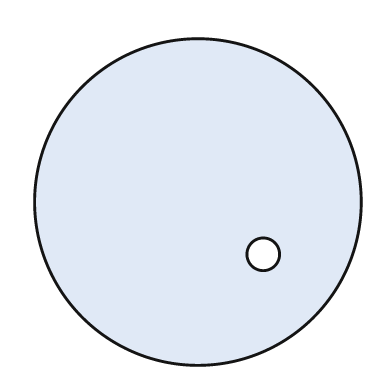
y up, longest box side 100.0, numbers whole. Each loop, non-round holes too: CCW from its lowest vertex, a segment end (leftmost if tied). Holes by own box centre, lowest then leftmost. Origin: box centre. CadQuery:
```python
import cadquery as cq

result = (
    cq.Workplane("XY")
    .moveTo(0.0, 0.0)
    .circle(50.0)
    .moveTo(20.0, -16.0)
    .circle(5.0)
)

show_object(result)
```